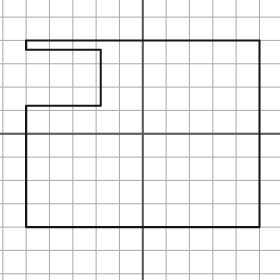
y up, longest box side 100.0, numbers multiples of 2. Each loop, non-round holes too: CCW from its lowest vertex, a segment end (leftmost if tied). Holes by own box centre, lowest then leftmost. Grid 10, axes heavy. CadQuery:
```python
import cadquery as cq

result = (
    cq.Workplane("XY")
    .moveTo(-50.0, -40.0)
    .lineTo(50.0, -40.0)
    .lineTo(50.0, 40.0)
    .lineTo(-50.0, 40.0)
    .lineTo(-50.0, 36.0)
    .lineTo(-18.0, 36.0)
    .lineTo(-18.0, 12.0)
    .lineTo(-50.0, 12.0)
    .close()
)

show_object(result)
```